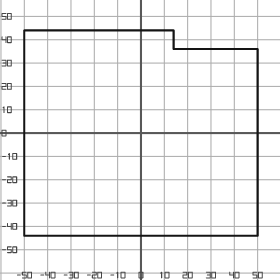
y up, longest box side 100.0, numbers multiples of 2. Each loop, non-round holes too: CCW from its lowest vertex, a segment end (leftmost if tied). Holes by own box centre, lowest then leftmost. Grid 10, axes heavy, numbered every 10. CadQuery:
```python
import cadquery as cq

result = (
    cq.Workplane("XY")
    .moveTo(-50.0, -44.0)
    .lineTo(50.0, -44.0)
    .lineTo(50.0, 36.0)
    .lineTo(14.0, 36.0)
    .lineTo(14.0, 44.0)
    .lineTo(-50.0, 44.0)
    .close()
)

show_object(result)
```